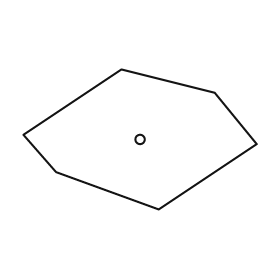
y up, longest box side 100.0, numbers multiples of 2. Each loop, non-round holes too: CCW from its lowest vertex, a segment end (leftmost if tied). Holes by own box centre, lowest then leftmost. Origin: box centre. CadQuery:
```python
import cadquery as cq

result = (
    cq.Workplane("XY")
    .moveTo(8.0, -30.0)
    .lineTo(50.0, -2.0)
    .lineTo(32.0, 20.0)
    .lineTo(-8.0, 30.0)
    .lineTo(-50.0, 2.0)
    .lineTo(-36.0, -14.0)
    .close()
    .moveTo(0.0, 0.0)
    .circle(2.0)
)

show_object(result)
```